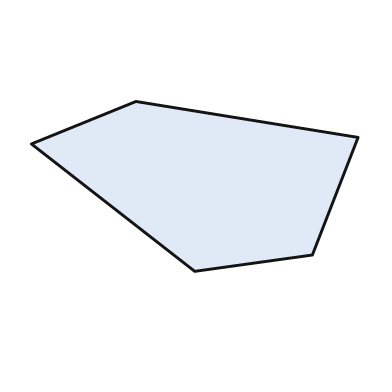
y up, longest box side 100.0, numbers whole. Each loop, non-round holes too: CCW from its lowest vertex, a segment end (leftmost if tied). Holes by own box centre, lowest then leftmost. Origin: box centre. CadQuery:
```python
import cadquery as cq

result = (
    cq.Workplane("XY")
    .moveTo(0.0, -26.0)
    .lineTo(36.0, -21.0)
    .lineTo(50.0, 15.0)
    .lineTo(-18.0, 26.0)
    .lineTo(-50.0, 13.0)
    .close()
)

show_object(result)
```